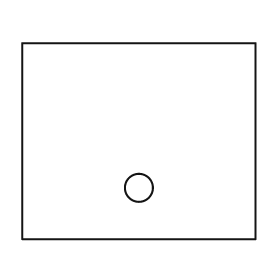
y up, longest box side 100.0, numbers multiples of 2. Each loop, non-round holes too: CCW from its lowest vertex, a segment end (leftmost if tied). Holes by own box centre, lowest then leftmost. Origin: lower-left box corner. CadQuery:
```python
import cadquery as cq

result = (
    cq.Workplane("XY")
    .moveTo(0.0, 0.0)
    .lineTo(100.0, 0.0)
    .lineTo(100.0, 84.0)
    .lineTo(0.0, 84.0)
    .close()
    .moveTo(50.0, 22.0)
    .circle(6.0)
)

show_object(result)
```